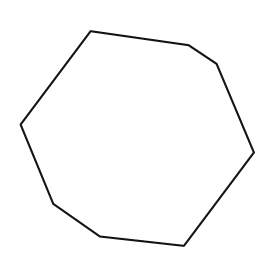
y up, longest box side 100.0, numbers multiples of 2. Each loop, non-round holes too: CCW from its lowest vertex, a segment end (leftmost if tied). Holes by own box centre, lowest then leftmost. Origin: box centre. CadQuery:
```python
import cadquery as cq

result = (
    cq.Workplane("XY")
    .moveTo(20.0, -46.0)
    .lineTo(50.0, -6.0)
    .lineTo(34.0, 32.0)
    .lineTo(22.0, 40.0)
    .lineTo(-20.0, 46.0)
    .lineTo(-50.0, 6.0)
    .lineTo(-36.0, -28.0)
    .lineTo(-16.0, -42.0)
    .close()
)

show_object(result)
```